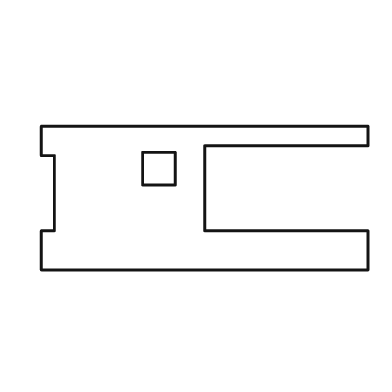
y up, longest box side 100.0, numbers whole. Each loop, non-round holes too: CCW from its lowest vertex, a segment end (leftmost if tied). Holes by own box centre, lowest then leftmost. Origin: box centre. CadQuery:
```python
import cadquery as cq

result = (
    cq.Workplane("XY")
    .moveTo(-50.0, -22.0)
    .lineTo(50.0, -22.0)
    .lineTo(50.0, -10.0)
    .lineTo(0.0, -10.0)
    .lineTo(0.0, 16.0)
    .lineTo(50.0, 16.0)
    .lineTo(50.0, 22.0)
    .lineTo(-50.0, 22.0)
    .lineTo(-50.0, 13.0)
    .lineTo(-46.0, 13.0)
    .lineTo(-46.0, -10.0)
    .lineTo(-50.0, -10.0)
    .close()
    .moveTo(-19.0, 4.0)
    .lineTo(-9.0, 4.0)
    .lineTo(-9.0, 14.0)
    .lineTo(-19.0, 14.0)
    .close()
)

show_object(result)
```